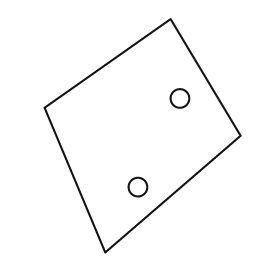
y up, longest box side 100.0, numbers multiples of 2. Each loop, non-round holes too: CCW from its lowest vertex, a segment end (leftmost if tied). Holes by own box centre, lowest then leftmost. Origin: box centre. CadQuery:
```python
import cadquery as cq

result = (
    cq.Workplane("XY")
    .moveTo(-16.0, -50.0)
    .lineTo(42.0, 0.0)
    .lineTo(12.0, 50.0)
    .lineTo(-42.0, 12.0)
    .close()
    .moveTo(-2.0, -22.0)
    .circle(4.0)
    .moveTo(16.0, 16.0)
    .circle(4.0)
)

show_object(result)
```